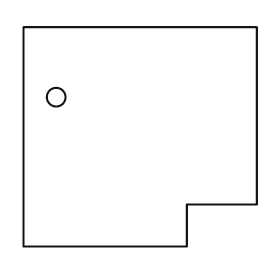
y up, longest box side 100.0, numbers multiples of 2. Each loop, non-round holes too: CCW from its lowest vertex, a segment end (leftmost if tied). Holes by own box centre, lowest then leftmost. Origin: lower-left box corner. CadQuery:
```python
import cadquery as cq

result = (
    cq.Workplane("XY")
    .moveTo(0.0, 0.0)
    .lineTo(70.0, 0.0)
    .lineTo(70.0, 18.0)
    .lineTo(100.0, 18.0)
    .lineTo(100.0, 94.0)
    .lineTo(0.0, 94.0)
    .close()
    .moveTo(14.0, 64.0)
    .circle(4.0)
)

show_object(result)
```